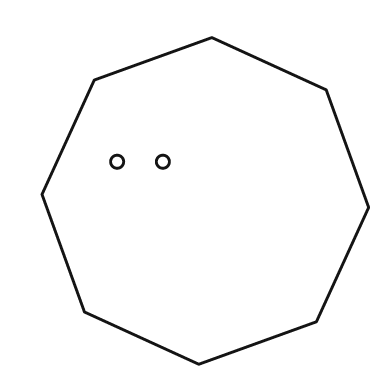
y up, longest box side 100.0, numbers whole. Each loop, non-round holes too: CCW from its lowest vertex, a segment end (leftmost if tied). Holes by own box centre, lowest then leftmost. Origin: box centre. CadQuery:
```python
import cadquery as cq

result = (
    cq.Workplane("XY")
    .moveTo(-2.0, -50.0)
    .lineTo(34.0, -37.0)
    .lineTo(50.0, -2.0)
    .lineTo(37.0, 34.0)
    .lineTo(2.0, 50.0)
    .lineTo(-34.0, 37.0)
    .lineTo(-50.0, 2.0)
    .lineTo(-37.0, -34.0)
    .close()
    .moveTo(-27.0, 12.0)
    .circle(2.0)
    .moveTo(-13.0, 12.0)
    .circle(2.0)
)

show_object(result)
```